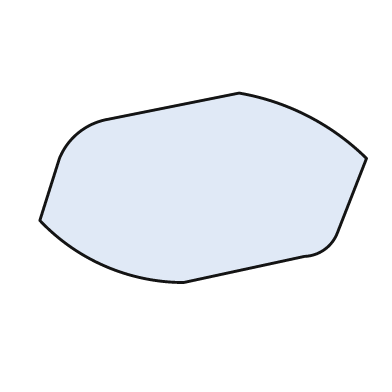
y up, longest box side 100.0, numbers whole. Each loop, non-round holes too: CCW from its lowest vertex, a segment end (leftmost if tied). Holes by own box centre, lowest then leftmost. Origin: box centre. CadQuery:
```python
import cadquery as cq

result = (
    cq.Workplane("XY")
    .moveTo(-6.0, -29.0)
    .lineTo(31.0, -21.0)
    .threePointArc((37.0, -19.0), (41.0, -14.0))
    .lineTo(50.0, 9.0)
    .threePointArc((32.0, 22.0), (11.0, 29.0))
    .lineTo(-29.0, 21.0)
    .threePointArc((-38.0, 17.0), (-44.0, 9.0))
    .lineTo(-50.0, -10.0)
    .threePointArc((-30.0, -24.0), (-6.0, -29.0))
    .close()
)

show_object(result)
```